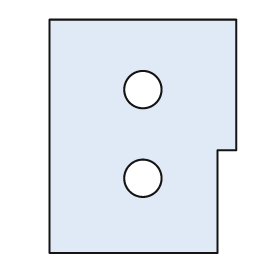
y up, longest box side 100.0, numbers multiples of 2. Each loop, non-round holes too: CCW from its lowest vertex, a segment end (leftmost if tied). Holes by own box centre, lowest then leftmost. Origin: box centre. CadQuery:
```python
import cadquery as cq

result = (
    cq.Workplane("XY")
    .moveTo(-40.0, -50.0)
    .lineTo(32.0, -50.0)
    .lineTo(32.0, -6.0)
    .lineTo(40.0, -6.0)
    .lineTo(40.0, 50.0)
    .lineTo(-40.0, 50.0)
    .close()
    .moveTo(0.0, -18.0)
    .circle(8.0)
    .moveTo(0.0, 20.0)
    .circle(8.0)
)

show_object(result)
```